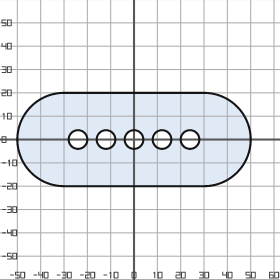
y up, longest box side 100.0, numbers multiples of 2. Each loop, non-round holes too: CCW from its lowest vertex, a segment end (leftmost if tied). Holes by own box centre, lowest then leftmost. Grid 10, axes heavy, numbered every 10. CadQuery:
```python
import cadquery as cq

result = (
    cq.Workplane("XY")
    .moveTo(-30.0, -20.0)
    .lineTo(30.0, -20.0)
    .threePointArc((50.0, 0.0), (30.0, 20.0))
    .lineTo(-30.0, 20.0)
    .threePointArc((-50.0, 0.0), (-30.0, -20.0))
    .close()
    .moveTo(-24.0, 0.0)
    .circle(4.0)
    .moveTo(-12.0, 0.0)
    .circle(4.0)
    .moveTo(0.0, 0.0)
    .circle(4.0)
    .moveTo(12.0, 0.0)
    .circle(4.0)
    .moveTo(24.0, 0.0)
    .circle(4.0)
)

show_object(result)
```